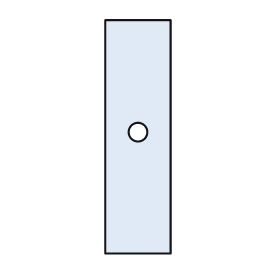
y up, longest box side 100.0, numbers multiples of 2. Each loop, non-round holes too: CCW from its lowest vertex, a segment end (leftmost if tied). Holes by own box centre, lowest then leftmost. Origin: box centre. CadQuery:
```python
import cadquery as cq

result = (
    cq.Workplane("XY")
    .moveTo(-14.0, -50.0)
    .lineTo(14.0, -50.0)
    .lineTo(14.0, 50.0)
    .lineTo(-14.0, 50.0)
    .close()
    .moveTo(0.0, 2.0)
    .circle(4.0)
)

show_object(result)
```